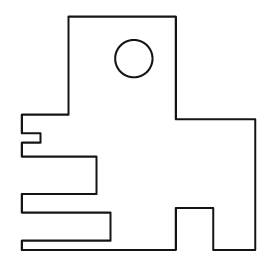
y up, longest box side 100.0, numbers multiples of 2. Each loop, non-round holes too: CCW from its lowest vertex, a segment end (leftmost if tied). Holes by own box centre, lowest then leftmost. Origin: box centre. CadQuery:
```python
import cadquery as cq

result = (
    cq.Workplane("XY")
    .moveTo(-50.0, -50.0)
    .lineTo(16.0, -50.0)
    .lineTo(16.0, -32.0)
    .lineTo(32.0, -32.0)
    .lineTo(32.0, -50.0)
    .lineTo(50.0, -50.0)
    .lineTo(50.0, 6.0)
    .lineTo(16.0, 6.0)
    .lineTo(16.0, 50.0)
    .lineTo(-30.0, 50.0)
    .lineTo(-30.0, 8.0)
    .lineTo(-50.0, 8.0)
    .lineTo(-50.0, 0.0)
    .lineTo(-42.0, 0.0)
    .lineTo(-42.0, -4.0)
    .lineTo(-50.0, -4.0)
    .lineTo(-50.0, -10.0)
    .lineTo(-18.0, -10.0)
    .lineTo(-18.0, -26.0)
    .lineTo(-50.0, -26.0)
    .lineTo(-50.0, -34.0)
    .lineTo(-12.0, -34.0)
    .lineTo(-12.0, -46.0)
    .lineTo(-50.0, -46.0)
    .close()
    .moveTo(-2.0, 32.0)
    .circle(8.0)
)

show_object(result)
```